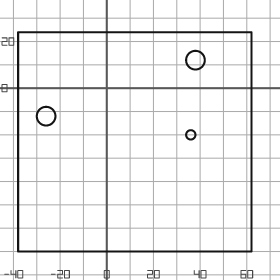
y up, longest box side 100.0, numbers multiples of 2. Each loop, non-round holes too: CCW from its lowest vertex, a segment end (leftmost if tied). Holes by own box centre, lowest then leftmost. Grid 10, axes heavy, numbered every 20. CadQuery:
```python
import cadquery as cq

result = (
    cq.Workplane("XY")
    .moveTo(-38.0, -70.0)
    .lineTo(62.0, -70.0)
    .lineTo(62.0, 24.0)
    .lineTo(-38.0, 24.0)
    .close()
    .moveTo(36.0, -20.0)
    .circle(2.0)
    .moveTo(-26.0, -12.0)
    .circle(4.0)
    .moveTo(38.0, 12.0)
    .circle(4.0)
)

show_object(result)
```